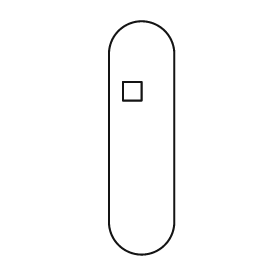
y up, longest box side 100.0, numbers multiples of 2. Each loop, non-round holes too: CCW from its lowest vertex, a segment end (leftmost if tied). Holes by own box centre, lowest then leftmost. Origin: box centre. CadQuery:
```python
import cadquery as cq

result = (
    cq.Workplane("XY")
    .moveTo(-14.0, -36.0)
    .threePointArc((0.0, -50.0), (14.0, -36.0))
    .lineTo(14.0, 36.0)
    .threePointArc((0.0, 50.0), (-14.0, 36.0))
    .close()
    .moveTo(-8.0, 16.0)
    .lineTo(0.0, 16.0)
    .lineTo(0.0, 24.0)
    .lineTo(-8.0, 24.0)
    .close()
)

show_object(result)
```